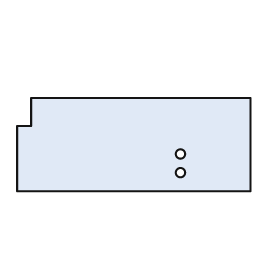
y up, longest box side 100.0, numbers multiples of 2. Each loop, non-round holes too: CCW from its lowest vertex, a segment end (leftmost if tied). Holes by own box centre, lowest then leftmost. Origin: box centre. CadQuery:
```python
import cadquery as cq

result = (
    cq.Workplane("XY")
    .moveTo(-50.0, -20.0)
    .lineTo(50.0, -20.0)
    .lineTo(50.0, 20.0)
    .lineTo(-44.0, 20.0)
    .lineTo(-44.0, 8.0)
    .lineTo(-50.0, 8.0)
    .close()
    .moveTo(20.0, -12.0)
    .circle(2.0)
    .moveTo(20.0, -4.0)
    .circle(2.0)
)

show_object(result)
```